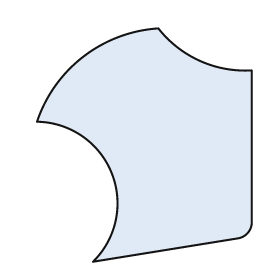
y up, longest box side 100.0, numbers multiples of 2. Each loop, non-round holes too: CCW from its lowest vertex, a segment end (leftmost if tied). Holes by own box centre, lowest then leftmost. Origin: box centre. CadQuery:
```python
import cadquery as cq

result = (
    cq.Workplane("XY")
    .moveTo(-22.0, -50.0)
    .lineTo(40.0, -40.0)
    .threePointArc((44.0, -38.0), (46.0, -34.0))
    .lineTo(46.0, 32.0)
    .threePointArc((24.0, 36.0), (6.0, 50.0))
    .threePointArc((-26.0, 38.0), (-46.0, 10.0))
    .threePointArc((-14.0, -12.0), (-22.0, -50.0))
    .close()
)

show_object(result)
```